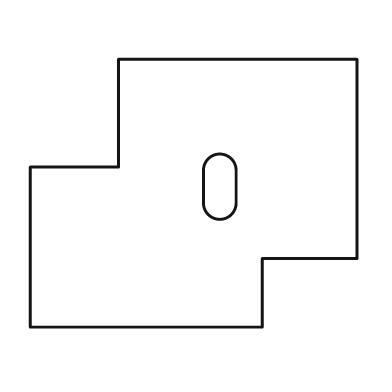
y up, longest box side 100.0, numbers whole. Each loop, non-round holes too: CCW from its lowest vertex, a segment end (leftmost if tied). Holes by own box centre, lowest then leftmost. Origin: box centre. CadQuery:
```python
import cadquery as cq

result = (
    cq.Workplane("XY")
    .moveTo(-50.0, -41.0)
    .lineTo(21.0, -41.0)
    .lineTo(21.0, -20.0)
    .lineTo(50.0, -20.0)
    .lineTo(50.0, 41.0)
    .lineTo(-23.0, 41.0)
    .lineTo(-23.0, 8.0)
    .lineTo(-50.0, 8.0)
    .close()
    .moveTo(3.0, -3.0)
    .threePointArc((8.0, -8.0), (13.0, -3.0))
    .lineTo(13.0, 7.0)
    .threePointArc((8.0, 12.0), (3.0, 7.0))
    .close()
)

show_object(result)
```